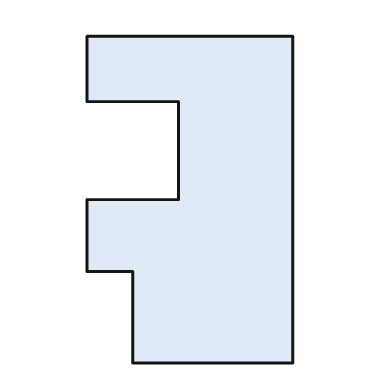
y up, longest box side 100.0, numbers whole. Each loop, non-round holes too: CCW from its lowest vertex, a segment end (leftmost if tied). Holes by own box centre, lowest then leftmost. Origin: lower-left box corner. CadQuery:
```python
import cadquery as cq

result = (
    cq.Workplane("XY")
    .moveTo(14.0, 0.0)
    .lineTo(63.0, 0.0)
    .lineTo(63.0, 100.0)
    .lineTo(0.0, 100.0)
    .lineTo(0.0, 80.0)
    .lineTo(28.0, 80.0)
    .lineTo(28.0, 50.0)
    .lineTo(0.0, 50.0)
    .lineTo(0.0, 28.0)
    .lineTo(14.0, 28.0)
    .close()
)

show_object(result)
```